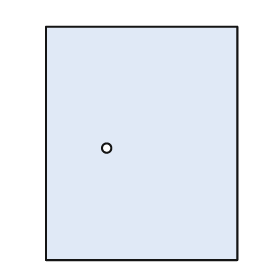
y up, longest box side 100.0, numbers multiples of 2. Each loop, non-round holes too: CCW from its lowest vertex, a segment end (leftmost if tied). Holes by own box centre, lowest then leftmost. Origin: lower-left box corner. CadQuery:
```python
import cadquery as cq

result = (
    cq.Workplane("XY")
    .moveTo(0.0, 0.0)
    .lineTo(82.0, 0.0)
    .lineTo(82.0, 100.0)
    .lineTo(0.0, 100.0)
    .close()
    .moveTo(26.0, 48.0)
    .circle(2.0)
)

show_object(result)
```